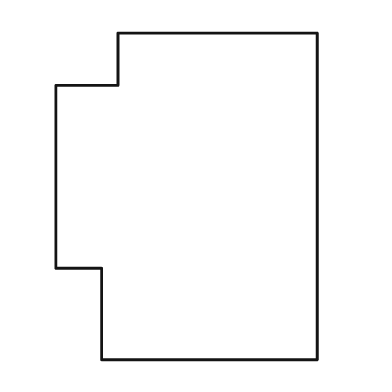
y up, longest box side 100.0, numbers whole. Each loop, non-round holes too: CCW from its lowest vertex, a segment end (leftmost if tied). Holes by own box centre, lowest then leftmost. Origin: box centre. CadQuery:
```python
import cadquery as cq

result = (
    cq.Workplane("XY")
    .moveTo(-26.0, -50.0)
    .lineTo(40.0, -50.0)
    .lineTo(40.0, 50.0)
    .lineTo(-21.0, 50.0)
    .lineTo(-21.0, 34.0)
    .lineTo(-40.0, 34.0)
    .lineTo(-40.0, -22.0)
    .lineTo(-26.0, -22.0)
    .close()
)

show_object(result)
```